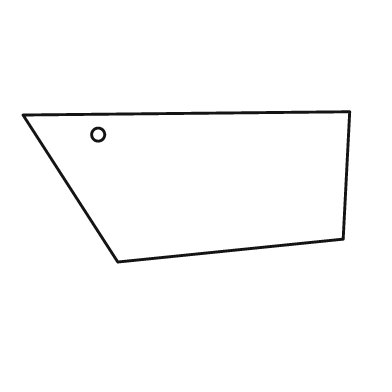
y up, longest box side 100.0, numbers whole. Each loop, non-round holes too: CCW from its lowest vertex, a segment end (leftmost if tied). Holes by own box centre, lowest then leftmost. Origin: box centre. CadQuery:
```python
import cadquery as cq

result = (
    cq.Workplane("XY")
    .moveTo(-21.0, -23.0)
    .lineTo(48.0, -16.0)
    .lineTo(50.0, 23.0)
    .lineTo(-50.0, 22.0)
    .close()
    .moveTo(-27.0, 16.0)
    .circle(2.0)
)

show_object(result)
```